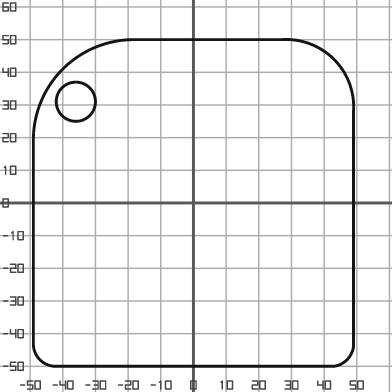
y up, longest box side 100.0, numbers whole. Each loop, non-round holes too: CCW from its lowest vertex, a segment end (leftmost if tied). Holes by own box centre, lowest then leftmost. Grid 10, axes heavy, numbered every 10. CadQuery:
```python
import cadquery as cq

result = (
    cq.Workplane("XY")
    .moveTo(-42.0, -50.0)
    .lineTo(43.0, -50.0)
    .threePointArc((47.0, -48.0), (49.0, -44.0))
    .lineTo(49.0, 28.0)
    .threePointArc((43.0, 44.0), (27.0, 50.0))
    .lineTo(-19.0, 50.0)
    .threePointArc((-40.0, 41.0), (-49.0, 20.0))
    .lineTo(-49.0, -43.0)
    .threePointArc((-47.0, -48.0), (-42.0, -50.0))
    .close()
    .moveTo(-36.0, 31.0)
    .circle(6.0)
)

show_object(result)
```